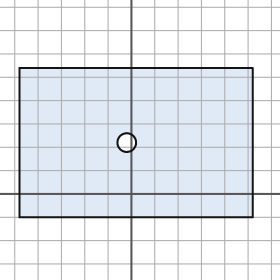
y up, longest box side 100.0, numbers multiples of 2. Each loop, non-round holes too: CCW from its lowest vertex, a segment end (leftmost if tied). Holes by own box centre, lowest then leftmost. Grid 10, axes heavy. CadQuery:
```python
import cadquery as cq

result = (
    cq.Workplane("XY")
    .moveTo(-48.0, -10.0)
    .lineTo(52.0, -10.0)
    .lineTo(52.0, 54.0)
    .lineTo(-48.0, 54.0)
    .close()
    .moveTo(-2.0, 22.0)
    .circle(4.0)
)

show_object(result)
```